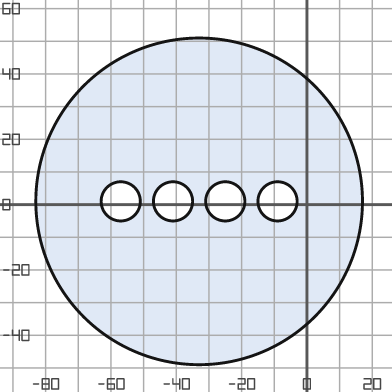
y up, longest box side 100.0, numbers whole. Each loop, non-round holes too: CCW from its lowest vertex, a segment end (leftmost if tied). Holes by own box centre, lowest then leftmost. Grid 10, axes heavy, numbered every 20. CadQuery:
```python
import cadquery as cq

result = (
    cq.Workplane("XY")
    .moveTo(-33.0, 1.0)
    .circle(50.0)
    .moveTo(-57.0, 1.0)
    .circle(6.0)
    .moveTo(-41.0, 1.0)
    .circle(6.0)
    .moveTo(-25.0, 1.0)
    .circle(6.0)
    .moveTo(-9.0, 1.0)
    .circle(6.0)
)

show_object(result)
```